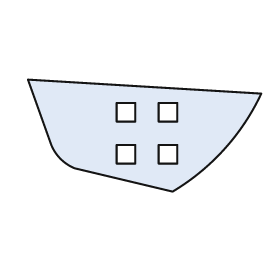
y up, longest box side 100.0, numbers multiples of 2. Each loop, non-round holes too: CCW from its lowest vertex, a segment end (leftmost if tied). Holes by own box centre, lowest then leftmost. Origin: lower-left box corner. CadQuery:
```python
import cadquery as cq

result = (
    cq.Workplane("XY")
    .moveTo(62.0, 0.0)
    .threePointArc((84.0, 18.0), (100.0, 42.0))
    .lineTo(0.0, 48.0)
    .lineTo(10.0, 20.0)
    .threePointArc((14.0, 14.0), (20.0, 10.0))
    .close()
    .moveTo(38.0, 12.0)
    .lineTo(46.0, 12.0)
    .lineTo(46.0, 20.0)
    .lineTo(38.0, 20.0)
    .close()
    .moveTo(56.0, 12.0)
    .lineTo(64.0, 12.0)
    .lineTo(64.0, 20.0)
    .lineTo(56.0, 20.0)
    .close()
    .moveTo(38.0, 30.0)
    .lineTo(46.0, 30.0)
    .lineTo(46.0, 38.0)
    .lineTo(38.0, 38.0)
    .close()
    .moveTo(56.0, 30.0)
    .lineTo(64.0, 30.0)
    .lineTo(64.0, 38.0)
    .lineTo(56.0, 38.0)
    .close()
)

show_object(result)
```